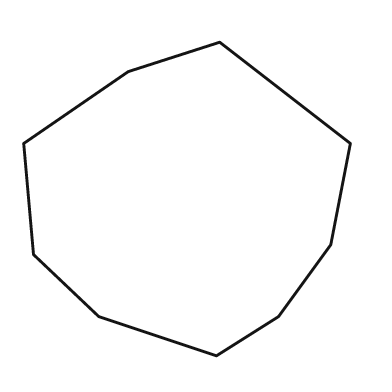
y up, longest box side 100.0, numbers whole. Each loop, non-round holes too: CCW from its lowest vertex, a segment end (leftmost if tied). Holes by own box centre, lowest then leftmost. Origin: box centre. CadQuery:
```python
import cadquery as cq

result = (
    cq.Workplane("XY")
    .moveTo(9.0, -48.0)
    .lineTo(28.0, -36.0)
    .lineTo(44.0, -14.0)
    .lineTo(50.0, 17.0)
    .lineTo(10.0, 48.0)
    .lineTo(-18.0, 39.0)
    .lineTo(-50.0, 17.0)
    .lineTo(-47.0, -17.0)
    .lineTo(-27.0, -36.0)
    .close()
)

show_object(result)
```